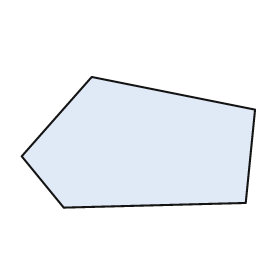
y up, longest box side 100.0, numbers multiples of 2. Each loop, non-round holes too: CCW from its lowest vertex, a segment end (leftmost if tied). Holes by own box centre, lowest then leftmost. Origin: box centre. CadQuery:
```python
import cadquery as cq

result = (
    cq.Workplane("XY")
    .moveTo(-32.0, -28.0)
    .lineTo(46.0, -26.0)
    .lineTo(50.0, 14.0)
    .lineTo(-20.0, 28.0)
    .lineTo(-50.0, -6.0)
    .close()
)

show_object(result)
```